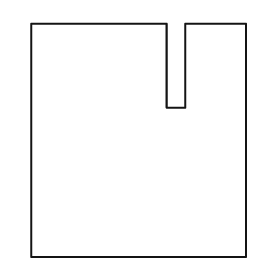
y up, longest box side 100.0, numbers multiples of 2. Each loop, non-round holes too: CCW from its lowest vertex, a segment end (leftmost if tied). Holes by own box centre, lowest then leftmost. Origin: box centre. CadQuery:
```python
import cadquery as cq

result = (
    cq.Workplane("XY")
    .moveTo(-46.0, -50.0)
    .lineTo(46.0, -50.0)
    .lineTo(46.0, 50.0)
    .lineTo(20.0, 50.0)
    .lineTo(20.0, 14.0)
    .lineTo(12.0, 14.0)
    .lineTo(12.0, 50.0)
    .lineTo(-46.0, 50.0)
    .close()
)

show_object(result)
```